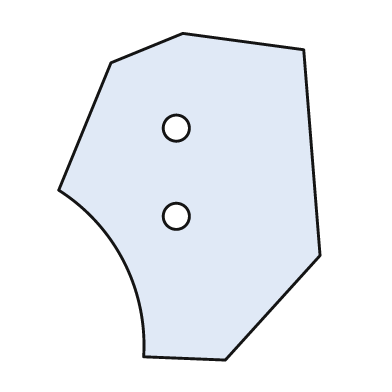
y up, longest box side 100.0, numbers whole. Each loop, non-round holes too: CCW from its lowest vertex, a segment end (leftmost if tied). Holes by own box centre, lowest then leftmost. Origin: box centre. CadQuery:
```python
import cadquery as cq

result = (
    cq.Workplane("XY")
    .moveTo(11.0, -50.0)
    .lineTo(40.0, -18.0)
    .lineTo(35.0, 45.0)
    .lineTo(-2.0, 50.0)
    .lineTo(-24.0, 41.0)
    .lineTo(-40.0, 2.0)
    .threePointArc((-20.0, -20.0), (-14.0, -49.0))
    .close()
    .moveTo(-4.0, -6.0)
    .circle(4.0)
    .moveTo(-4.0, 21.0)
    .circle(4.0)
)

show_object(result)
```